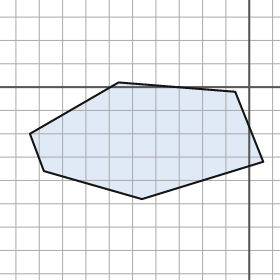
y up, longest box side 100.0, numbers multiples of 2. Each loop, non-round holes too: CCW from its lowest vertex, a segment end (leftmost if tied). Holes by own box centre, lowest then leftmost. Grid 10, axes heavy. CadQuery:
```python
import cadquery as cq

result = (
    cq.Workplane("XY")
    .moveTo(-46.0, -48.0)
    .lineTo(6.0, -32.0)
    .lineTo(-6.0, -2.0)
    .lineTo(-56.0, 2.0)
    .lineTo(-94.0, -20.0)
    .lineTo(-88.0, -36.0)
    .close()
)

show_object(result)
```